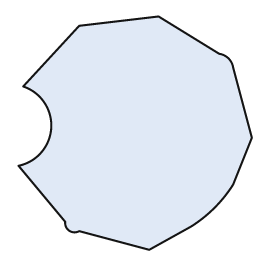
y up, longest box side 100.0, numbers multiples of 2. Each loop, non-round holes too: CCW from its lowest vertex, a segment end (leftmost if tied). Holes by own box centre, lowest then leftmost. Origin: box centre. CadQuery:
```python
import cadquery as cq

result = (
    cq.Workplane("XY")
    .moveTo(6.0, -50.0)
    .lineTo(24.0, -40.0)
    .threePointArc((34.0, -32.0), (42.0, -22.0))
    .lineTo(50.0, -2.0)
    .lineTo(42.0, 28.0)
    .threePointArc((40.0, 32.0), (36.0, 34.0))
    .lineTo(10.0, 50.0)
    .lineTo(-24.0, 46.0)
    .lineTo(-48.0, 20.0)
    .threePointArc((-36.0, 2.0), (-50.0, -14.0))
    .lineTo(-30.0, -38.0)
    .threePointArc((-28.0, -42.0), (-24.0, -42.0))
    .close()
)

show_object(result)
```